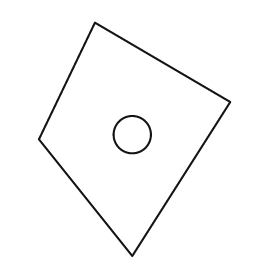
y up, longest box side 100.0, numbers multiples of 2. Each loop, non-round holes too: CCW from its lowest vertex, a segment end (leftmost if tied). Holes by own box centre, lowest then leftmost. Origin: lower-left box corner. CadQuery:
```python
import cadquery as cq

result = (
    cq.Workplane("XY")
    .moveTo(40.0, 0.0)
    .lineTo(82.0, 66.0)
    .lineTo(24.0, 100.0)
    .lineTo(0.0, 50.0)
    .close()
    .moveTo(40.0, 52.0)
    .circle(8.0)
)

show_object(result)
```